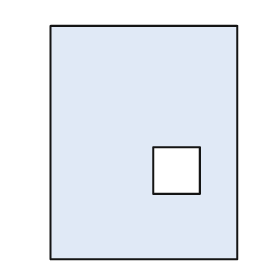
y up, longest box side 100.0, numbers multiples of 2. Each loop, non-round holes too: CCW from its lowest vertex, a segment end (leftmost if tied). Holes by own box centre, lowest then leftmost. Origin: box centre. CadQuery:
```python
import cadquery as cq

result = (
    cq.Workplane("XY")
    .moveTo(-40.0, -50.0)
    .lineTo(40.0, -50.0)
    .lineTo(40.0, 50.0)
    .lineTo(-40.0, 50.0)
    .close()
    .moveTo(4.0, -22.0)
    .lineTo(24.0, -22.0)
    .lineTo(24.0, -2.0)
    .lineTo(4.0, -2.0)
    .close()
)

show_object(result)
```